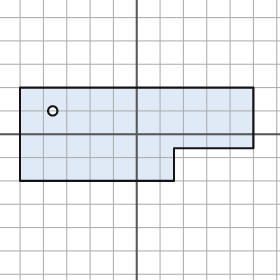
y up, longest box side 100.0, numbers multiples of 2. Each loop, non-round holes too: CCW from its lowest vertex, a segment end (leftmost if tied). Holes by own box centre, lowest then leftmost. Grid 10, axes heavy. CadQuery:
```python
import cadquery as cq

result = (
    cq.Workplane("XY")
    .moveTo(-50.0, -20.0)
    .lineTo(16.0, -20.0)
    .lineTo(16.0, -6.0)
    .lineTo(50.0, -6.0)
    .lineTo(50.0, 20.0)
    .lineTo(-50.0, 20.0)
    .close()
    .moveTo(-36.0, 10.0)
    .circle(2.0)
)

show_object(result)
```